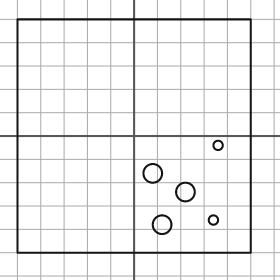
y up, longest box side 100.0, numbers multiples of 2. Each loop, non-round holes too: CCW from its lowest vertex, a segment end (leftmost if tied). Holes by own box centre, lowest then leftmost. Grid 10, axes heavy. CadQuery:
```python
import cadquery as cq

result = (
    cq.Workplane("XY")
    .moveTo(-50.0, -50.0)
    .lineTo(50.0, -50.0)
    .lineTo(50.0, 50.0)
    .lineTo(-50.0, 50.0)
    .close()
    .moveTo(12.0, -38.0)
    .circle(4.0)
    .moveTo(34.0, -36.0)
    .circle(2.0)
    .moveTo(22.0, -24.0)
    .circle(4.0)
    .moveTo(8.0, -16.0)
    .circle(4.0)
    .moveTo(36.0, -4.0)
    .circle(2.0)
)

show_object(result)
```